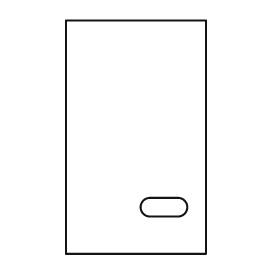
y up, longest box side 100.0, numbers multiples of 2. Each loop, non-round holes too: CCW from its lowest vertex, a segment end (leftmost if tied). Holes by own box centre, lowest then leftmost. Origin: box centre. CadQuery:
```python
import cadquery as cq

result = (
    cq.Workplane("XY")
    .moveTo(-30.0, -50.0)
    .lineTo(30.0, -50.0)
    .lineTo(30.0, 50.0)
    .lineTo(-30.0, 50.0)
    .close()
    .moveTo(6.0, -34.0)
    .lineTo(18.0, -34.0)
    .threePointArc((22.0, -30.0), (18.0, -26.0))
    .lineTo(6.0, -26.0)
    .threePointArc((2.0, -30.0), (6.0, -34.0))
    .close()
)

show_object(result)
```